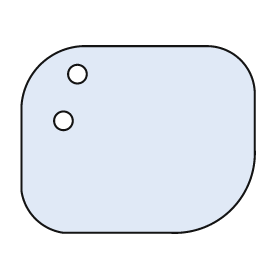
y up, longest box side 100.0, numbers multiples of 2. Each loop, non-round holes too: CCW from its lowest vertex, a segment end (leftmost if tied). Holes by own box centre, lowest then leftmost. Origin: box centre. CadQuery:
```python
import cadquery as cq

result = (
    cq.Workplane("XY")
    .moveTo(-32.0, -40.0)
    .lineTo(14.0, -40.0)
    .threePointArc((40.0, -30.0), (50.0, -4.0))
    .lineTo(50.0, 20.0)
    .threePointArc((44.0, 34.0), (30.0, 40.0))
    .lineTo(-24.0, 40.0)
    .threePointArc((-42.0, 32.0), (-50.0, 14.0))
    .lineTo(-50.0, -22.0)
    .threePointArc((-44.0, -34.0), (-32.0, -40.0))
    .close()
    .moveTo(-32.0, 8.0)
    .circle(4.0)
    .moveTo(-26.0, 28.0)
    .circle(4.0)
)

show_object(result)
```